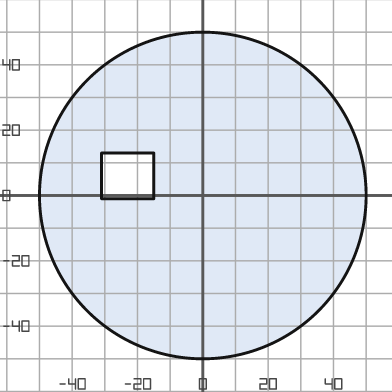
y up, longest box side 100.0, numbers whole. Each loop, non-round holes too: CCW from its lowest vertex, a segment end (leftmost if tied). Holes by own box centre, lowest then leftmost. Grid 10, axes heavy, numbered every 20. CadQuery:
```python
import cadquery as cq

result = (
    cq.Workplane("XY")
    .moveTo(0.0, 0.0)
    .circle(50.0)
    .moveTo(-31.0, -1.0)
    .lineTo(-15.0, -1.0)
    .lineTo(-15.0, 13.0)
    .lineTo(-31.0, 13.0)
    .close()
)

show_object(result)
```